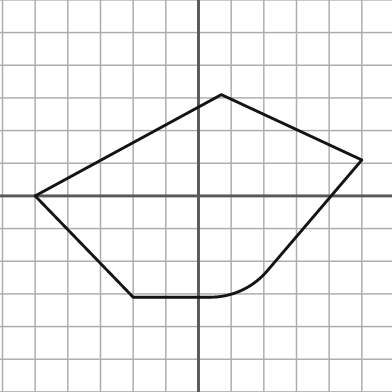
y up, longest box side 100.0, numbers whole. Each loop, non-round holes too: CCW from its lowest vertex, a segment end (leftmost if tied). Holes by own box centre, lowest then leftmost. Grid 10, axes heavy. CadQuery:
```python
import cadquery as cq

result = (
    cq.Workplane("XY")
    .moveTo(-20.0, -31.0)
    .lineTo(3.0, -31.0)
    .threePointArc((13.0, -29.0), (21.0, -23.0))
    .lineTo(50.0, 11.0)
    .lineTo(7.0, 31.0)
    .lineTo(-50.0, 0.0)
    .close()
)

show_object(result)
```